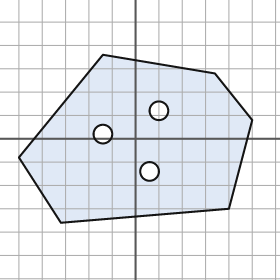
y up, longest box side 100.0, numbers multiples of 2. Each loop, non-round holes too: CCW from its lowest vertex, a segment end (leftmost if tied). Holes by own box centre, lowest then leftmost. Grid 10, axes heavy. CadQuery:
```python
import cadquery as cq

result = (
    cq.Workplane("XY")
    .moveTo(-32.0, -36.0)
    .lineTo(40.0, -30.0)
    .lineTo(50.0, 8.0)
    .lineTo(34.0, 28.0)
    .lineTo(-14.0, 36.0)
    .lineTo(-50.0, -8.0)
    .close()
    .moveTo(6.0, -14.0)
    .circle(4.0)
    .moveTo(-14.0, 2.0)
    .circle(4.0)
    .moveTo(10.0, 12.0)
    .circle(4.0)
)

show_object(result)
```